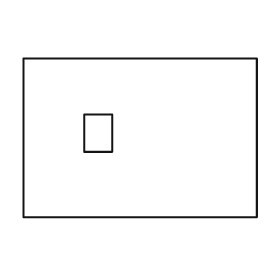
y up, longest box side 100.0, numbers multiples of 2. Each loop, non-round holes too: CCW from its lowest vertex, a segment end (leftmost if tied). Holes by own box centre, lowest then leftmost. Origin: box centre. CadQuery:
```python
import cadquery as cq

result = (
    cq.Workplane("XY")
    .moveTo(-50.0, -34.0)
    .lineTo(50.0, -34.0)
    .lineTo(50.0, 34.0)
    .lineTo(-50.0, 34.0)
    .close()
    .moveTo(-24.0, -6.0)
    .lineTo(-12.0, -6.0)
    .lineTo(-12.0, 10.0)
    .lineTo(-24.0, 10.0)
    .close()
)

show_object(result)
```